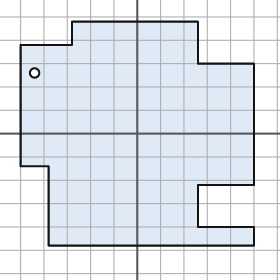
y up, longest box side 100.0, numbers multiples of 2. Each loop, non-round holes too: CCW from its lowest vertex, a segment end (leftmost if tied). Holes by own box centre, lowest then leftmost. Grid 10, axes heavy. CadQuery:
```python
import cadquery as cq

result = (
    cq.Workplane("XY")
    .moveTo(-38.0, -48.0)
    .lineTo(50.0, -48.0)
    .lineTo(50.0, -40.0)
    .lineTo(26.0, -40.0)
    .lineTo(26.0, -22.0)
    .lineTo(50.0, -22.0)
    .lineTo(50.0, 30.0)
    .lineTo(26.0, 30.0)
    .lineTo(26.0, 48.0)
    .lineTo(-28.0, 48.0)
    .lineTo(-28.0, 38.0)
    .lineTo(-50.0, 38.0)
    .lineTo(-50.0, -14.0)
    .lineTo(-38.0, -14.0)
    .close()
    .moveTo(-44.0, 26.0)
    .circle(2.0)
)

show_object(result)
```